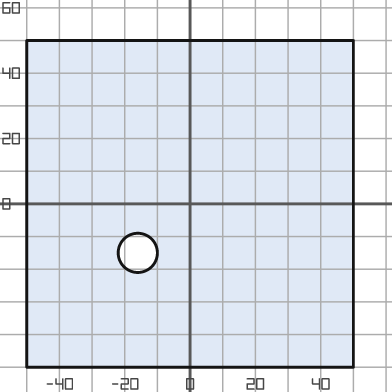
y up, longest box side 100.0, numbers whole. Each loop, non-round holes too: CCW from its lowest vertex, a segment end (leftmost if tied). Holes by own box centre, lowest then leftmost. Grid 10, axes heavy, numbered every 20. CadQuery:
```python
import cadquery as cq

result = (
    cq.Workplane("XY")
    .moveTo(-50.0, -50.0)
    .lineTo(50.0, -50.0)
    .lineTo(50.0, 50.0)
    .lineTo(-50.0, 50.0)
    .close()
    .moveTo(-16.0, -15.0)
    .circle(6.0)
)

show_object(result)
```